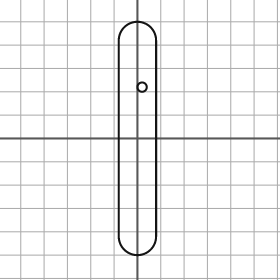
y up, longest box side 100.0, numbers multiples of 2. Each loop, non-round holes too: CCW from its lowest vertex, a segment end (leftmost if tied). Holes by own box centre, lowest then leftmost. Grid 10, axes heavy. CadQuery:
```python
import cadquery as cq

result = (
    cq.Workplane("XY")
    .moveTo(-8.0, -42.0)
    .threePointArc((0.0, -50.0), (8.0, -42.0))
    .lineTo(8.0, 42.0)
    .threePointArc((0.0, 50.0), (-8.0, 42.0))
    .close()
    .moveTo(2.0, 22.0)
    .circle(2.0)
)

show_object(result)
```